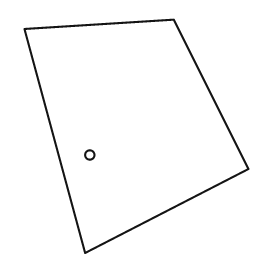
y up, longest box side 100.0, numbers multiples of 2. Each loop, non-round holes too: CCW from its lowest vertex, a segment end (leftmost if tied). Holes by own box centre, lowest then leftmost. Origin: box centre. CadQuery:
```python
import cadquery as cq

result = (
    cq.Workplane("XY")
    .moveTo(-22.0, -50.0)
    .lineTo(48.0, -14.0)
    .lineTo(16.0, 50.0)
    .lineTo(-48.0, 46.0)
    .close()
    .moveTo(-20.0, -8.0)
    .circle(2.0)
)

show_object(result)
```